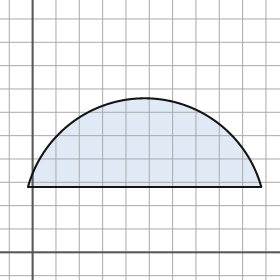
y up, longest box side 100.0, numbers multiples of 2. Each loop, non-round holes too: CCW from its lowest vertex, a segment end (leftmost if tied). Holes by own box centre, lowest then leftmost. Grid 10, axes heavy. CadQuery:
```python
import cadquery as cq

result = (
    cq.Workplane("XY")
    .moveTo(-2.0, 28.0)
    .lineTo(98.0, 28.0)
    .threePointArc((48.0, 66.0), (-2.0, 28.0))
    .close()
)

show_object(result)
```